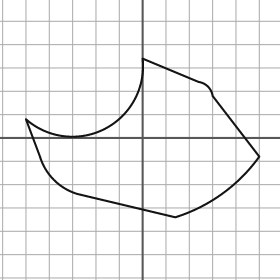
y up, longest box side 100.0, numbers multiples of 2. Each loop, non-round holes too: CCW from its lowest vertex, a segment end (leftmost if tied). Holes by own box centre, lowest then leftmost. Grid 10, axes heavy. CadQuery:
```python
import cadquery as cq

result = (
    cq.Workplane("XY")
    .moveTo(14.0, -34.0)
    .threePointArc((34.0, -24.0), (50.0, -8.0))
    .lineTo(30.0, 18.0)
    .threePointArc((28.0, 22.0), (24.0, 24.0))
    .lineTo(0.0, 34.0)
    .threePointArc((-16.0, 4.0), (-50.0, 8.0))
    .lineTo(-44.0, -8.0)
    .threePointArc((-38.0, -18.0), (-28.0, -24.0))
    .close()
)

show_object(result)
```